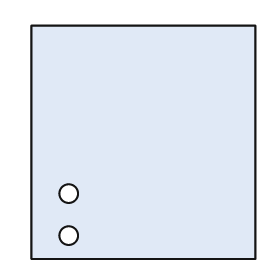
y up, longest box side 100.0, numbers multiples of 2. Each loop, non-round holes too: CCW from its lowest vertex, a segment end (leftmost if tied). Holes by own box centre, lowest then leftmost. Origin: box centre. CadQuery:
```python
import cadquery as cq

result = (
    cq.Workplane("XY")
    .moveTo(-48.0, -50.0)
    .lineTo(48.0, -50.0)
    .lineTo(48.0, 50.0)
    .lineTo(-48.0, 50.0)
    .close()
    .moveTo(-32.0, -40.0)
    .circle(4.0)
    .moveTo(-32.0, -22.0)
    .circle(4.0)
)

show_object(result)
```